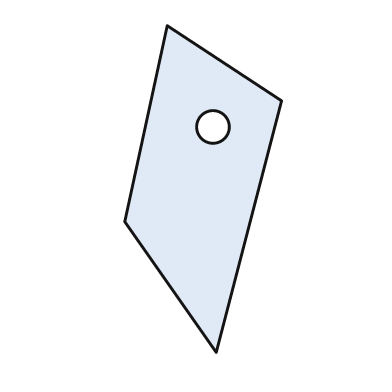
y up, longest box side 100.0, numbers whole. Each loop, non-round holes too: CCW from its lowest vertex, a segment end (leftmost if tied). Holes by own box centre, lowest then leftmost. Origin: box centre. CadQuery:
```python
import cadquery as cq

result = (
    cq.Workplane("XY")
    .moveTo(4.0, -50.0)
    .lineTo(24.0, 27.0)
    .lineTo(-11.0, 50.0)
    .lineTo(-24.0, -10.0)
    .close()
    .moveTo(3.0, 19.0)
    .circle(5.0)
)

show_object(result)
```